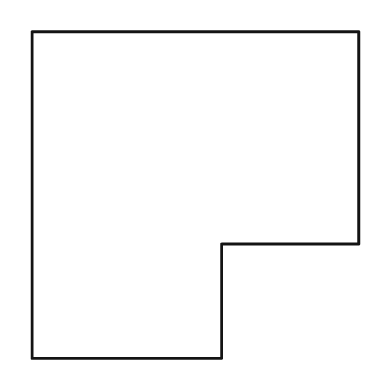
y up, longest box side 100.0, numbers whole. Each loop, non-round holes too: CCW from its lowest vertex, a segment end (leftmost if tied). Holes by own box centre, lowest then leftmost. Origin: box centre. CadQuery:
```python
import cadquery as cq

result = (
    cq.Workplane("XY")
    .moveTo(-50.0, -50.0)
    .lineTo(8.0, -50.0)
    .lineTo(8.0, -15.0)
    .lineTo(50.0, -15.0)
    .lineTo(50.0, 50.0)
    .lineTo(-50.0, 50.0)
    .close()
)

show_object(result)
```